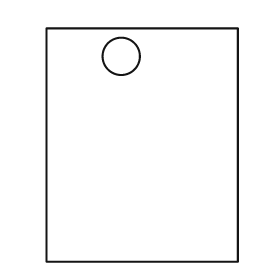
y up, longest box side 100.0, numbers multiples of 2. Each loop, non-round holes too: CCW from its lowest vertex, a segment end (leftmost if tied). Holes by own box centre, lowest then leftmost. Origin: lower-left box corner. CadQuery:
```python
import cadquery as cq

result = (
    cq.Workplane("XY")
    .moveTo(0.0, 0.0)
    .lineTo(82.0, 0.0)
    .lineTo(82.0, 100.0)
    .lineTo(0.0, 100.0)
    .close()
    .moveTo(32.0, 88.0)
    .circle(8.0)
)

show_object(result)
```